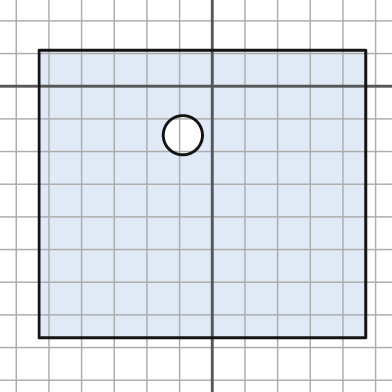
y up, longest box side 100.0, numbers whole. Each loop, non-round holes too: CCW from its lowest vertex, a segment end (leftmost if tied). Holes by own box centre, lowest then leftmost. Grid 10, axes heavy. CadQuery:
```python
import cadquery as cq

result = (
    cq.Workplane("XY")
    .moveTo(-53.0, -77.0)
    .lineTo(47.0, -77.0)
    .lineTo(47.0, 11.0)
    .lineTo(-53.0, 11.0)
    .close()
    .moveTo(-9.0, -15.0)
    .circle(6.0)
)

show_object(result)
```